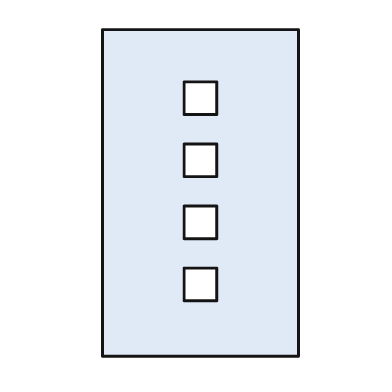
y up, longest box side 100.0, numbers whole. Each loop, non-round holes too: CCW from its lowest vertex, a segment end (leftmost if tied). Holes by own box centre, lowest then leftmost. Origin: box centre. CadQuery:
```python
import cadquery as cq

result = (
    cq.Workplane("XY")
    .moveTo(-30.0, -50.0)
    .lineTo(30.0, -50.0)
    .lineTo(30.0, 50.0)
    .lineTo(-30.0, 50.0)
    .close()
    .moveTo(-5.0, -33.0)
    .lineTo(5.0, -33.0)
    .lineTo(5.0, -23.0)
    .lineTo(-5.0, -23.0)
    .close()
    .moveTo(-5.0, -14.0)
    .lineTo(5.0, -14.0)
    .lineTo(5.0, -4.0)
    .lineTo(-5.0, -4.0)
    .close()
    .moveTo(-5.0, 5.0)
    .lineTo(5.0, 5.0)
    .lineTo(5.0, 15.0)
    .lineTo(-5.0, 15.0)
    .close()
    .moveTo(-5.0, 24.0)
    .lineTo(5.0, 24.0)
    .lineTo(5.0, 34.0)
    .lineTo(-5.0, 34.0)
    .close()
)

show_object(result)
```